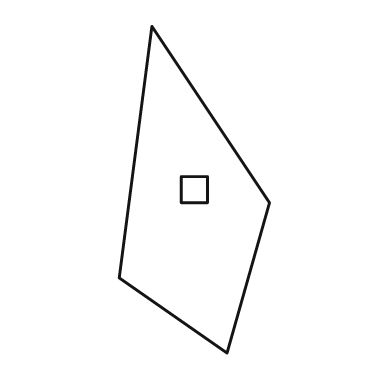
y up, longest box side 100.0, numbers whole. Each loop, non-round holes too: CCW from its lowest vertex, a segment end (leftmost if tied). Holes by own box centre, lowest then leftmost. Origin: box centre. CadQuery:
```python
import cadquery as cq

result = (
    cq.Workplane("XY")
    .moveTo(10.0, -50.0)
    .lineTo(23.0, -4.0)
    .lineTo(-13.0, 50.0)
    .lineTo(-23.0, -27.0)
    .close()
    .moveTo(-4.0, -4.0)
    .lineTo(4.0, -4.0)
    .lineTo(4.0, 4.0)
    .lineTo(-4.0, 4.0)
    .close()
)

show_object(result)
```